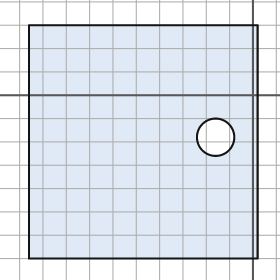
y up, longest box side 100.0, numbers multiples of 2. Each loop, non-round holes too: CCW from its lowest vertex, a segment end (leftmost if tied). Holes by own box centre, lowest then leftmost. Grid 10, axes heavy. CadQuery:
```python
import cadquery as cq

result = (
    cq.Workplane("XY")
    .moveTo(-96.0, -70.0)
    .lineTo(2.0, -70.0)
    .lineTo(2.0, 30.0)
    .lineTo(-96.0, 30.0)
    .close()
    .moveTo(-16.0, -18.0)
    .circle(8.0)
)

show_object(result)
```